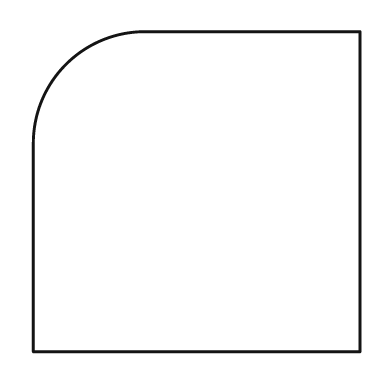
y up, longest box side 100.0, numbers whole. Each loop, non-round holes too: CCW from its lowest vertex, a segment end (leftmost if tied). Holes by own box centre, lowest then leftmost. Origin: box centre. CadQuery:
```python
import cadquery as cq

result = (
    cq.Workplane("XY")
    .moveTo(-50.0, -49.0)
    .lineTo(50.0, -49.0)
    .lineTo(50.0, 49.0)
    .lineTo(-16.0, 49.0)
    .threePointArc((-40.0, 39.0), (-50.0, 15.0))
    .close()
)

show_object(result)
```